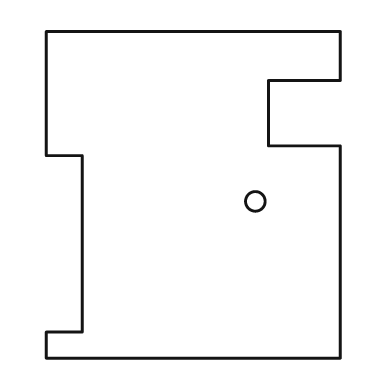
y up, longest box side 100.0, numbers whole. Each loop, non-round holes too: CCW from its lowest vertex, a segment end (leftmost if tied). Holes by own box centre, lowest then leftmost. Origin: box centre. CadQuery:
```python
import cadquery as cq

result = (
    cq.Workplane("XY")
    .moveTo(-45.0, -50.0)
    .lineTo(45.0, -50.0)
    .lineTo(45.0, 15.0)
    .lineTo(23.0, 15.0)
    .lineTo(23.0, 35.0)
    .lineTo(45.0, 35.0)
    .lineTo(45.0, 50.0)
    .lineTo(-45.0, 50.0)
    .lineTo(-45.0, 12.0)
    .lineTo(-34.0, 12.0)
    .lineTo(-34.0, -42.0)
    .lineTo(-45.0, -42.0)
    .close()
    .moveTo(19.0, -2.0)
    .circle(3.0)
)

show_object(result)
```